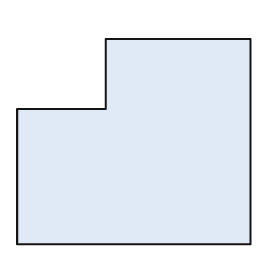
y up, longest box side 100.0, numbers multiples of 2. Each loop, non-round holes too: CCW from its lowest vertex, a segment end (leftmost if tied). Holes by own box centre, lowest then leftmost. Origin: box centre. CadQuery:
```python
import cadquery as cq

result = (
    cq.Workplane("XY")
    .moveTo(-50.0, -44.0)
    .lineTo(50.0, -44.0)
    .lineTo(50.0, 44.0)
    .lineTo(-12.0, 44.0)
    .lineTo(-12.0, 14.0)
    .lineTo(-50.0, 14.0)
    .close()
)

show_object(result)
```